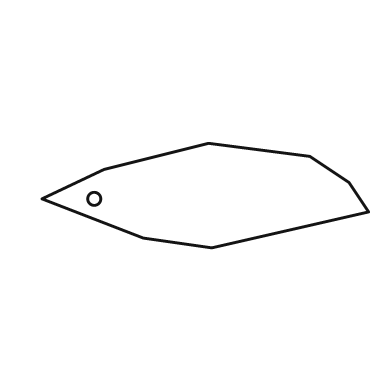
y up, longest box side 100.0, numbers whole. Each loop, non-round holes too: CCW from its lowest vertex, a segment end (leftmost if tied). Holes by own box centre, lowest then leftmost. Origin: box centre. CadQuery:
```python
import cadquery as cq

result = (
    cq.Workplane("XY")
    .moveTo(2.0, -16.0)
    .lineTo(50.0, -5.0)
    .lineTo(44.0, 4.0)
    .lineTo(32.0, 12.0)
    .lineTo(1.0, 16.0)
    .lineTo(-31.0, 8.0)
    .lineTo(-50.0, -1.0)
    .lineTo(-19.0, -13.0)
    .close()
    .moveTo(-34.0, -1.0)
    .circle(2.0)
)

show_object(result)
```